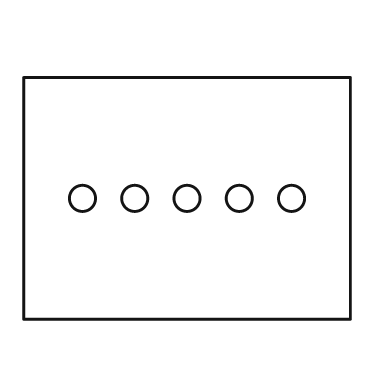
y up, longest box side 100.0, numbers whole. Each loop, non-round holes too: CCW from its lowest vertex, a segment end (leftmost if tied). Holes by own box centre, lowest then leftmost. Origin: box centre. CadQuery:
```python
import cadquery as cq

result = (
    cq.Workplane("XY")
    .moveTo(-50.0, -37.0)
    .lineTo(50.0, -37.0)
    .lineTo(50.0, 37.0)
    .lineTo(-50.0, 37.0)
    .close()
    .moveTo(-32.0, 0.0)
    .circle(4.0)
    .moveTo(-16.0, 0.0)
    .circle(4.0)
    .moveTo(0.0, 0.0)
    .circle(4.0)
    .moveTo(16.0, 0.0)
    .circle(4.0)
    .moveTo(32.0, 0.0)
    .circle(4.0)
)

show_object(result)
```